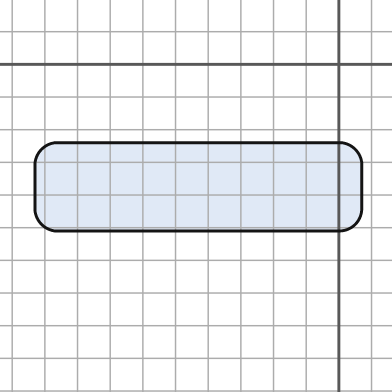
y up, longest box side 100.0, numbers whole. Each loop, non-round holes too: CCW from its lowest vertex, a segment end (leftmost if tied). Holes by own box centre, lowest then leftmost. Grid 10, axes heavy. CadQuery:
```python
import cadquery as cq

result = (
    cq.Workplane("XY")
    .moveTo(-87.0, -51.0)
    .lineTo(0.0, -51.0)
    .threePointArc((5.0, -49.0), (7.0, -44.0))
    .lineTo(7.0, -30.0)
    .threePointArc((5.0, -26.0), (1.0, -24.0))
    .lineTo(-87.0, -24.0)
    .threePointArc((-91.0, -26.0), (-93.0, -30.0))
    .lineTo(-93.0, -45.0)
    .threePointArc((-91.0, -49.0), (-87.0, -51.0))
    .close()
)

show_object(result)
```